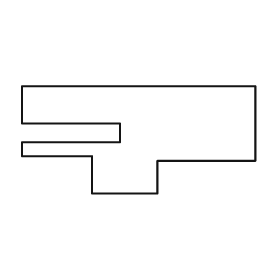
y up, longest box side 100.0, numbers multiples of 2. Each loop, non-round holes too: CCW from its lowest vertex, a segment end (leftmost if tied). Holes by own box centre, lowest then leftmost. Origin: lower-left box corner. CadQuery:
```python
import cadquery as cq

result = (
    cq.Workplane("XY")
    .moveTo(30.0, 0.0)
    .lineTo(58.0, 0.0)
    .lineTo(58.0, 14.0)
    .lineTo(100.0, 14.0)
    .lineTo(100.0, 46.0)
    .lineTo(0.0, 46.0)
    .lineTo(0.0, 30.0)
    .lineTo(42.0, 30.0)
    .lineTo(42.0, 22.0)
    .lineTo(0.0, 22.0)
    .lineTo(0.0, 16.0)
    .lineTo(30.0, 16.0)
    .close()
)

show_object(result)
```